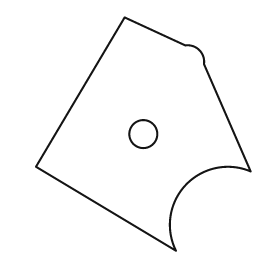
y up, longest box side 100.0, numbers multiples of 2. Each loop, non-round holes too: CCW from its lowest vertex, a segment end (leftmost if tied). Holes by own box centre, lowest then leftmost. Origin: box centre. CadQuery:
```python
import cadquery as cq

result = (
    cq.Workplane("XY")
    .moveTo(14.0, -50.0)
    .threePointArc((18.0, -22.0), (46.0, -16.0))
    .lineTo(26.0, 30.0)
    .threePointArc((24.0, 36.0), (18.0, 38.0))
    .lineTo(-8.0, 50.0)
    .lineTo(-46.0, -14.0)
    .close()
    .moveTo(0.0, 0.0)
    .circle(6.0)
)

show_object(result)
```